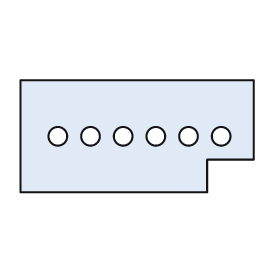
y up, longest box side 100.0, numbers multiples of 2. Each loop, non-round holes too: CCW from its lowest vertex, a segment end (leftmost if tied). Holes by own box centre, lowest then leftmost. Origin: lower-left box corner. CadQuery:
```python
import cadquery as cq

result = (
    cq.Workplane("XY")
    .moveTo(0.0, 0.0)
    .lineTo(80.0, 0.0)
    .lineTo(80.0, 14.0)
    .lineTo(100.0, 14.0)
    .lineTo(100.0, 48.0)
    .lineTo(0.0, 48.0)
    .close()
    .moveTo(16.0, 24.0)
    .circle(4.0)
    .moveTo(30.0, 24.0)
    .circle(4.0)
    .moveTo(44.0, 24.0)
    .circle(4.0)
    .moveTo(58.0, 24.0)
    .circle(4.0)
    .moveTo(72.0, 24.0)
    .circle(4.0)
    .moveTo(86.0, 24.0)
    .circle(4.0)
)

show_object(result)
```